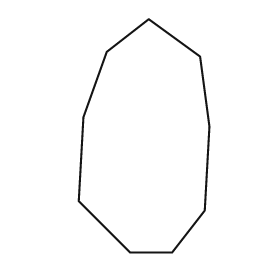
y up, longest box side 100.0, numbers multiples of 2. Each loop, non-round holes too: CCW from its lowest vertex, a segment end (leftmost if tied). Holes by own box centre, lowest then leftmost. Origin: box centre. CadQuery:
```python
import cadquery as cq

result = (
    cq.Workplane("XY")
    .moveTo(-6.0, -50.0)
    .lineTo(12.0, -50.0)
    .lineTo(26.0, -32.0)
    .lineTo(28.0, 4.0)
    .lineTo(24.0, 34.0)
    .lineTo(2.0, 50.0)
    .lineTo(-16.0, 36.0)
    .lineTo(-26.0, 8.0)
    .lineTo(-28.0, -28.0)
    .close()
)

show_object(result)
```